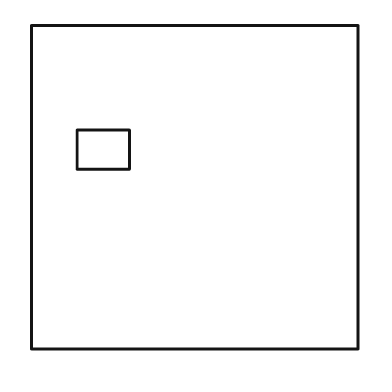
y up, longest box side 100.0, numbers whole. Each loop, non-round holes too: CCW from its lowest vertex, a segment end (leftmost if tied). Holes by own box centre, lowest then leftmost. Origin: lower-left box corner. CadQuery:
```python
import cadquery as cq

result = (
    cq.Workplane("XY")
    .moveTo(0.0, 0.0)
    .lineTo(100.0, 0.0)
    .lineTo(100.0, 99.0)
    .lineTo(0.0, 99.0)
    .close()
    .moveTo(14.0, 55.0)
    .lineTo(30.0, 55.0)
    .lineTo(30.0, 67.0)
    .lineTo(14.0, 67.0)
    .close()
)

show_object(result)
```